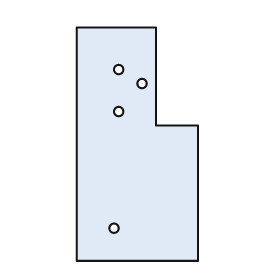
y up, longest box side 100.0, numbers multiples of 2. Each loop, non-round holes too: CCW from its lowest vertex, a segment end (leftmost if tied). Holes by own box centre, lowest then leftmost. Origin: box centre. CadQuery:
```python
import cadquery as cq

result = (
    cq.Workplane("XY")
    .moveTo(-26.0, -50.0)
    .lineTo(26.0, -50.0)
    .lineTo(26.0, 8.0)
    .lineTo(8.0, 8.0)
    .lineTo(8.0, 50.0)
    .lineTo(-26.0, 50.0)
    .close()
    .moveTo(-10.0, -36.0)
    .circle(2.0)
    .moveTo(-8.0, 14.0)
    .circle(2.0)
    .moveTo(2.0, 26.0)
    .circle(2.0)
    .moveTo(-8.0, 32.0)
    .circle(2.0)
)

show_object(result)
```